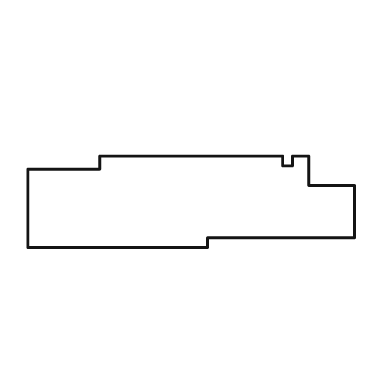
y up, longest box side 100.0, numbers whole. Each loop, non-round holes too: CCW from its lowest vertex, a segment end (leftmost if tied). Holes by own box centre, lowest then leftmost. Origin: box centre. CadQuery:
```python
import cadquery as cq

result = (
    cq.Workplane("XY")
    .moveTo(-50.0, -14.0)
    .lineTo(5.0, -14.0)
    .lineTo(5.0, -11.0)
    .lineTo(50.0, -11.0)
    .lineTo(50.0, 5.0)
    .lineTo(36.0, 5.0)
    .lineTo(36.0, 14.0)
    .lineTo(31.0, 14.0)
    .lineTo(31.0, 11.0)
    .lineTo(28.0, 11.0)
    .lineTo(28.0, 14.0)
    .lineTo(-28.0, 14.0)
    .lineTo(-28.0, 10.0)
    .lineTo(-50.0, 10.0)
    .close()
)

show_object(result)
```